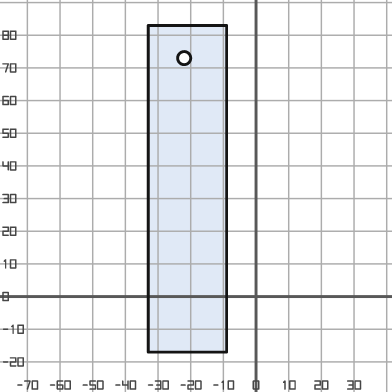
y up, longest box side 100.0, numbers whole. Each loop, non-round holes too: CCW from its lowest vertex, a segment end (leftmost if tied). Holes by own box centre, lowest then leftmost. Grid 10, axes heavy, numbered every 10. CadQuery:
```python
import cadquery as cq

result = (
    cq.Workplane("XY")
    .moveTo(-33.0, -17.0)
    .lineTo(-9.0, -17.0)
    .lineTo(-9.0, 83.0)
    .lineTo(-33.0, 83.0)
    .close()
    .moveTo(-22.0, 73.0)
    .circle(2.0)
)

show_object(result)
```